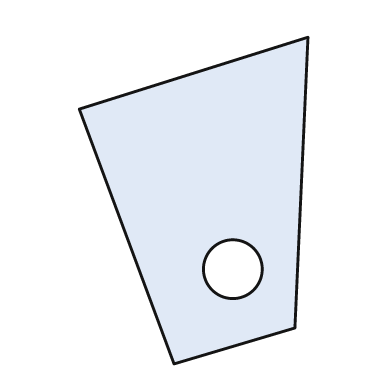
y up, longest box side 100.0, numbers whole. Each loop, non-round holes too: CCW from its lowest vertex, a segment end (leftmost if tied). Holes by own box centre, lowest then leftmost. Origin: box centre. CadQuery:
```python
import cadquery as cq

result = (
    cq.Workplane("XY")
    .moveTo(-6.0, -50.0)
    .lineTo(31.0, -39.0)
    .lineTo(35.0, 50.0)
    .lineTo(-35.0, 28.0)
    .close()
    .moveTo(12.0, -21.0)
    .circle(9.0)
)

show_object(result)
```